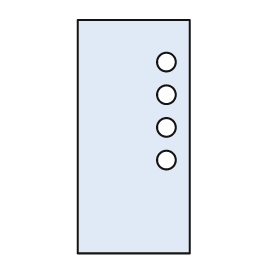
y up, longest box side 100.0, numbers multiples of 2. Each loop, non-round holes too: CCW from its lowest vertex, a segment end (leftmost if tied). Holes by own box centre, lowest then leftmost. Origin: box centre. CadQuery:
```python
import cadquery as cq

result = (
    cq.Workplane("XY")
    .moveTo(-24.0, -50.0)
    .lineTo(24.0, -50.0)
    .lineTo(24.0, 50.0)
    .lineTo(-24.0, 50.0)
    .close()
    .moveTo(14.0, -10.0)
    .circle(4.0)
    .moveTo(14.0, 4.0)
    .circle(4.0)
    .moveTo(14.0, 18.0)
    .circle(4.0)
    .moveTo(14.0, 32.0)
    .circle(4.0)
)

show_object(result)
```